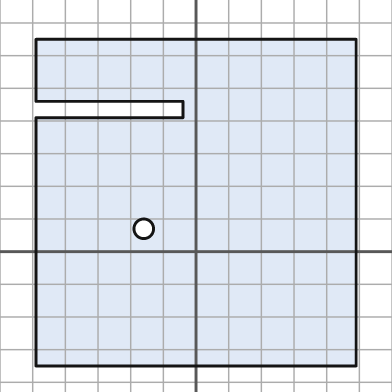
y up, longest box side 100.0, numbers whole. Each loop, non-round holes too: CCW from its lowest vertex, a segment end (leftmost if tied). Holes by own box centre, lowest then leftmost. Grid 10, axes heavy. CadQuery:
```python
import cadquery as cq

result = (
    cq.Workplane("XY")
    .moveTo(-49.0, -35.0)
    .lineTo(49.0, -35.0)
    .lineTo(49.0, 65.0)
    .lineTo(-49.0, 65.0)
    .lineTo(-49.0, 46.0)
    .lineTo(-4.0, 46.0)
    .lineTo(-4.0, 41.0)
    .lineTo(-49.0, 41.0)
    .close()
    .moveTo(-16.0, 7.0)
    .circle(3.0)
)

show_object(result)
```